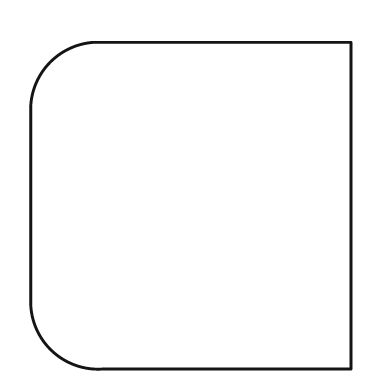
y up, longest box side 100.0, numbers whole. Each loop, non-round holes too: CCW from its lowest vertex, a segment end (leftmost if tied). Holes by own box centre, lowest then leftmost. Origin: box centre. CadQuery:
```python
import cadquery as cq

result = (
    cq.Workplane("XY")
    .moveTo(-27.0, -50.0)
    .lineTo(49.0, -50.0)
    .lineTo(49.0, 50.0)
    .lineTo(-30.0, 50.0)
    .threePointArc((-43.0, 44.0), (-49.0, 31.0))
    .lineTo(-49.0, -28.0)
    .threePointArc((-43.0, -44.0), (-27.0, -50.0))
    .close()
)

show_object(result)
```